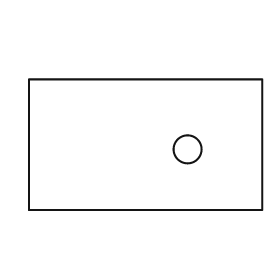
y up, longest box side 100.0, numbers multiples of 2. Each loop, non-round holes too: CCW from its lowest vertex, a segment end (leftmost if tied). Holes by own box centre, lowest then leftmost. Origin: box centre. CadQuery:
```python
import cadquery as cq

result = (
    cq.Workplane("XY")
    .moveTo(-50.0, -28.0)
    .lineTo(50.0, -28.0)
    .lineTo(50.0, 28.0)
    .lineTo(-50.0, 28.0)
    .close()
    .moveTo(18.0, -2.0)
    .circle(6.0)
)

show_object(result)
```